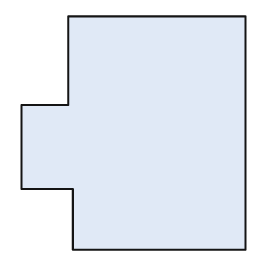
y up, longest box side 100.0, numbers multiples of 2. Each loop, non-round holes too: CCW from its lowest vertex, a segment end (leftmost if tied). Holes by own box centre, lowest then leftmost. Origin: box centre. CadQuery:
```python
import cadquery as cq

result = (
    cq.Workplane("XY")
    .moveTo(-26.0, -50.0)
    .lineTo(48.0, -50.0)
    .lineTo(48.0, 50.0)
    .lineTo(-28.0, 50.0)
    .lineTo(-28.0, 12.0)
    .lineTo(-48.0, 12.0)
    .lineTo(-48.0, -24.0)
    .lineTo(-26.0, -24.0)
    .close()
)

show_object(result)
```